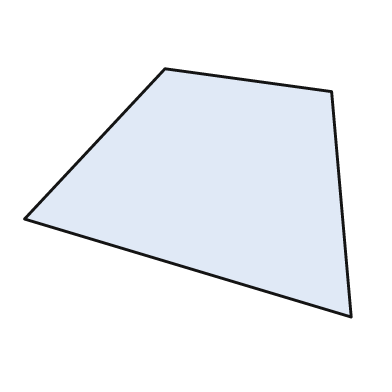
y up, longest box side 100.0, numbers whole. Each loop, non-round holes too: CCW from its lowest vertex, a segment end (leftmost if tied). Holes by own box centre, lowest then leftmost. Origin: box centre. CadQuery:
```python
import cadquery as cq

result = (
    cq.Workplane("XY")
    .moveTo(50.0, -38.0)
    .lineTo(44.0, 31.0)
    .lineTo(-7.0, 38.0)
    .lineTo(-50.0, -8.0)
    .close()
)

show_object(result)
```